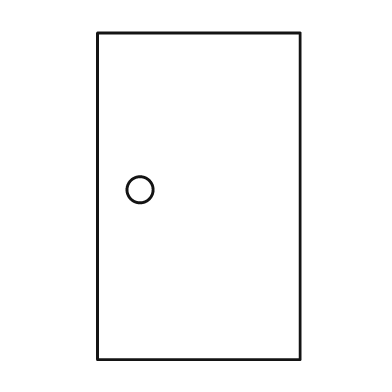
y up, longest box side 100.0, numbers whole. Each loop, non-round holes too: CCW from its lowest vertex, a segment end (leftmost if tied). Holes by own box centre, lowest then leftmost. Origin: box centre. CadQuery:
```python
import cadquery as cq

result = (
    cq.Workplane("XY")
    .moveTo(-31.0, -50.0)
    .lineTo(31.0, -50.0)
    .lineTo(31.0, 50.0)
    .lineTo(-31.0, 50.0)
    .close()
    .moveTo(-18.0, 2.0)
    .circle(4.0)
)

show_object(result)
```